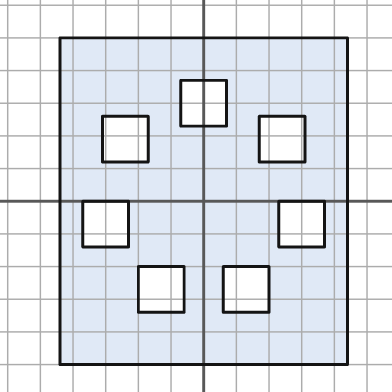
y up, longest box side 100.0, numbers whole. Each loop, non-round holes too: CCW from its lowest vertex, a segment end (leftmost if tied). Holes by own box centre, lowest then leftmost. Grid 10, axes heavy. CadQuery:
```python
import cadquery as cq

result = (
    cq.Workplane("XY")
    .moveTo(-44.0, -50.0)
    .lineTo(44.0, -50.0)
    .lineTo(44.0, 50.0)
    .lineTo(-44.0, 50.0)
    .close()
    .moveTo(-20.0, -34.0)
    .lineTo(-6.0, -34.0)
    .lineTo(-6.0, -20.0)
    .lineTo(-20.0, -20.0)
    .close()
    .moveTo(6.0, -34.0)
    .lineTo(20.0, -34.0)
    .lineTo(20.0, -20.0)
    .lineTo(6.0, -20.0)
    .close()
    .moveTo(-37.0, -14.0)
    .lineTo(-23.0, -14.0)
    .lineTo(-23.0, 0.0)
    .lineTo(-37.0, 0.0)
    .close()
    .moveTo(23.0, -14.0)
    .lineTo(37.0, -14.0)
    .lineTo(37.0, 0.0)
    .lineTo(23.0, 0.0)
    .close()
    .moveTo(-31.0, 12.0)
    .lineTo(-17.0, 12.0)
    .lineTo(-17.0, 26.0)
    .lineTo(-31.0, 26.0)
    .close()
    .moveTo(17.0, 12.0)
    .lineTo(31.0, 12.0)
    .lineTo(31.0, 26.0)
    .lineTo(17.0, 26.0)
    .close()
    .moveTo(-7.0, 23.0)
    .lineTo(7.0, 23.0)
    .lineTo(7.0, 37.0)
    .lineTo(-7.0, 37.0)
    .close()
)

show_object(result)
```